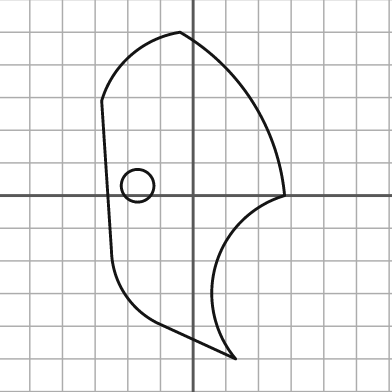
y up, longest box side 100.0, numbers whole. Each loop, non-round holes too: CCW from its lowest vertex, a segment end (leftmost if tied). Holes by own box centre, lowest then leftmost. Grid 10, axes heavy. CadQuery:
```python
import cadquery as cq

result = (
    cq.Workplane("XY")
    .moveTo(13.0, -50.0)
    .threePointArc((7.0, -21.0), (28.0, 0.0))
    .threePointArc((18.0, 29.0), (-4.0, 50.0))
    .threePointArc((-19.0, 43.0), (-28.0, 29.0))
    .lineTo(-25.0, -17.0)
    .threePointArc((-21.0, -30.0), (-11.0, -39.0))
    .close()
    .moveTo(-17.0, 3.0)
    .circle(5.0)
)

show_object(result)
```